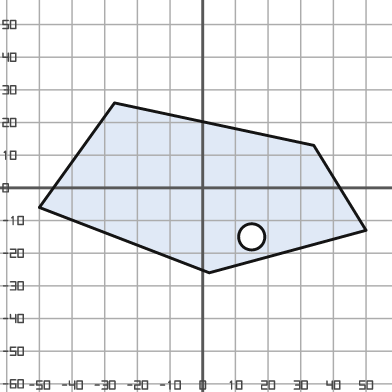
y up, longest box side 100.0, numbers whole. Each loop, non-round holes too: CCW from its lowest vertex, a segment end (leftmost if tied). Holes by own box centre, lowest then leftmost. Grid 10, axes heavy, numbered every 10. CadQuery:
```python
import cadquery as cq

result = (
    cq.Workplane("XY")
    .moveTo(2.0, -26.0)
    .lineTo(50.0, -13.0)
    .lineTo(34.0, 13.0)
    .lineTo(-27.0, 26.0)
    .lineTo(-50.0, -6.0)
    .close()
    .moveTo(15.0, -15.0)
    .circle(4.0)
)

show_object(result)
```